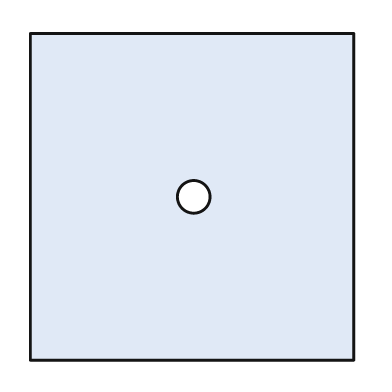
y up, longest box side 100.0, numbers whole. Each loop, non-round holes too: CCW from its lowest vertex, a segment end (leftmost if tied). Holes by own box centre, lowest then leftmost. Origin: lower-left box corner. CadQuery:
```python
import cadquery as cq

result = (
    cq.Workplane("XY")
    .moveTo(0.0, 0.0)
    .lineTo(99.0, 0.0)
    .lineTo(99.0, 100.0)
    .lineTo(0.0, 100.0)
    .close()
    .moveTo(50.0, 50.0)
    .circle(5.0)
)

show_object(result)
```